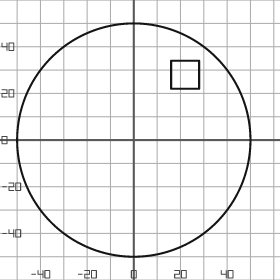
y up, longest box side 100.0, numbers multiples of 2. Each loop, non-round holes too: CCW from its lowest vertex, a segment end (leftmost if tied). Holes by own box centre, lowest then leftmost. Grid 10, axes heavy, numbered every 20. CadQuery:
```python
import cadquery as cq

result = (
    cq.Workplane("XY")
    .moveTo(0.0, 0.0)
    .circle(50.0)
    .moveTo(16.0, 22.0)
    .lineTo(28.0, 22.0)
    .lineTo(28.0, 34.0)
    .lineTo(16.0, 34.0)
    .close()
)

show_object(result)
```